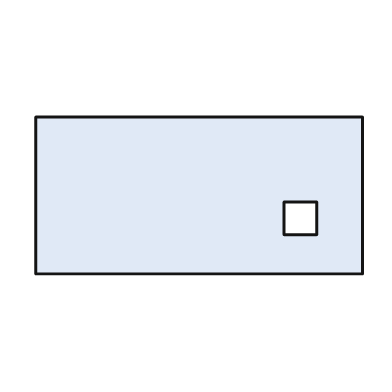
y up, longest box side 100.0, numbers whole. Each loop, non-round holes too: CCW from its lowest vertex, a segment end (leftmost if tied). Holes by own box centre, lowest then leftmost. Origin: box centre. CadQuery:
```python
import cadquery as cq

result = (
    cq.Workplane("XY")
    .moveTo(-50.0, -24.0)
    .lineTo(50.0, -24.0)
    .lineTo(50.0, 24.0)
    .lineTo(-50.0, 24.0)
    .close()
    .moveTo(26.0, -12.0)
    .lineTo(36.0, -12.0)
    .lineTo(36.0, -2.0)
    .lineTo(26.0, -2.0)
    .close()
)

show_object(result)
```